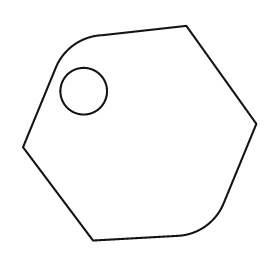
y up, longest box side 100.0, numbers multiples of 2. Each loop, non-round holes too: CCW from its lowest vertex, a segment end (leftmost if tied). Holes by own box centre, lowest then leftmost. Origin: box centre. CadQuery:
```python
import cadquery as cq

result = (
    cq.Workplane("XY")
    .moveTo(-20.0, -46.0)
    .lineTo(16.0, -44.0)
    .threePointArc((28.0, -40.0), (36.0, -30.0))
    .lineTo(50.0, 4.0)
    .lineTo(20.0, 46.0)
    .lineTo(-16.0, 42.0)
    .threePointArc((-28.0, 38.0), (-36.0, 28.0))
    .lineTo(-50.0, -6.0)
    .close()
    .moveTo(-24.0, 18.0)
    .circle(10.0)
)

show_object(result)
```